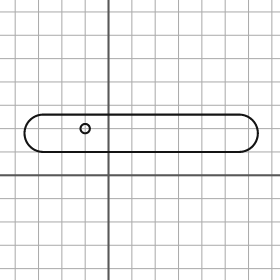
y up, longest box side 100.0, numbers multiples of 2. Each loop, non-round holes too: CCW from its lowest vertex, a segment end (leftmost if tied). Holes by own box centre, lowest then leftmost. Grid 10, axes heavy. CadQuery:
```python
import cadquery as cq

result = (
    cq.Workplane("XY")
    .moveTo(-28.0, 10.0)
    .lineTo(56.0, 10.0)
    .threePointArc((64.0, 18.0), (56.0, 26.0))
    .lineTo(-28.0, 26.0)
    .threePointArc((-36.0, 18.0), (-28.0, 10.0))
    .close()
    .moveTo(-10.0, 20.0)
    .circle(2.0)
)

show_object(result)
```